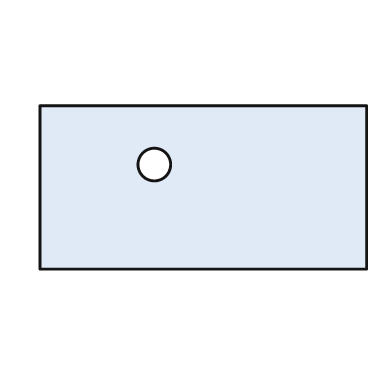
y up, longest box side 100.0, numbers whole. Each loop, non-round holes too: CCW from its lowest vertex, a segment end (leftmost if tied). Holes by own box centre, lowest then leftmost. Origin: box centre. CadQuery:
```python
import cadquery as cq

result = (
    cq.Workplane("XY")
    .moveTo(-50.0, -25.0)
    .lineTo(50.0, -25.0)
    .lineTo(50.0, 25.0)
    .lineTo(-50.0, 25.0)
    .close()
    .moveTo(-15.0, 7.0)
    .circle(5.0)
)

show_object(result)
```